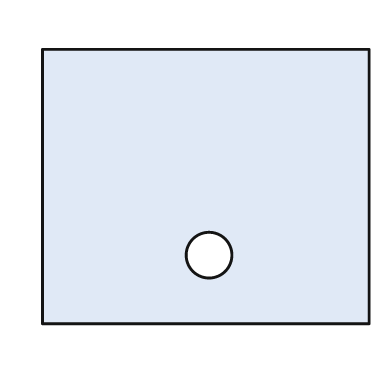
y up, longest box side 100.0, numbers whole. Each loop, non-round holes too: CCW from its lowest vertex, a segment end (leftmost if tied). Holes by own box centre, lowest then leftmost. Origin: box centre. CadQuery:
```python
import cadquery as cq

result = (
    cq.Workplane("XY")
    .moveTo(-50.0, -42.0)
    .lineTo(50.0, -42.0)
    .lineTo(50.0, 42.0)
    .lineTo(-50.0, 42.0)
    .close()
    .moveTo(1.0, -21.0)
    .circle(7.0)
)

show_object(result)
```